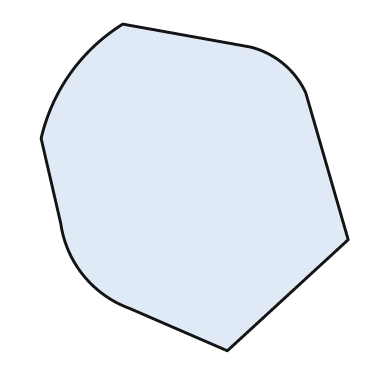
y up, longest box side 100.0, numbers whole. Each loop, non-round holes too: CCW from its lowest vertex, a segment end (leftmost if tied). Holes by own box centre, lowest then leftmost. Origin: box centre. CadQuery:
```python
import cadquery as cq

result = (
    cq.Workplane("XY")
    .moveTo(10.0, -50.0)
    .lineTo(47.0, -16.0)
    .lineTo(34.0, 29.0)
    .threePointArc((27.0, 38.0), (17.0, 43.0))
    .lineTo(-22.0, 50.0)
    .threePointArc((-38.0, 35.0), (-47.0, 15.0))
    .lineTo(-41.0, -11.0)
    .threePointArc((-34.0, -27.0), (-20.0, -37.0))
    .close()
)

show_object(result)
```